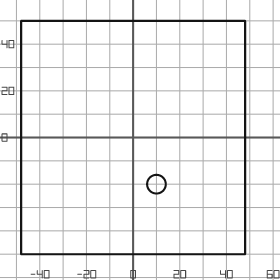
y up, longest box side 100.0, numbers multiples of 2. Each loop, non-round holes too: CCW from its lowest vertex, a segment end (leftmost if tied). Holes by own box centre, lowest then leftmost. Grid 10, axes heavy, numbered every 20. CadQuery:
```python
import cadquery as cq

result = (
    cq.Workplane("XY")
    .moveTo(-48.0, -50.0)
    .lineTo(48.0, -50.0)
    .lineTo(48.0, 50.0)
    .lineTo(-48.0, 50.0)
    .close()
    .moveTo(10.0, -20.0)
    .circle(4.0)
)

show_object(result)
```